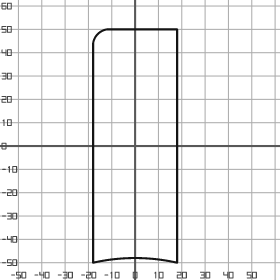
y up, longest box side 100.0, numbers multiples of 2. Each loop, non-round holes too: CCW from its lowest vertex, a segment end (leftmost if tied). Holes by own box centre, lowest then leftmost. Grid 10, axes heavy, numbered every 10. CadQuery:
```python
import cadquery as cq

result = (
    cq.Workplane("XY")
    .moveTo(-18.0, -50.0)
    .threePointArc((0.0, -48.0), (18.0, -50.0))
    .lineTo(18.0, 50.0)
    .lineTo(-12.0, 50.0)
    .threePointArc((-16.0, 48.0), (-18.0, 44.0))
    .close()
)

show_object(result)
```